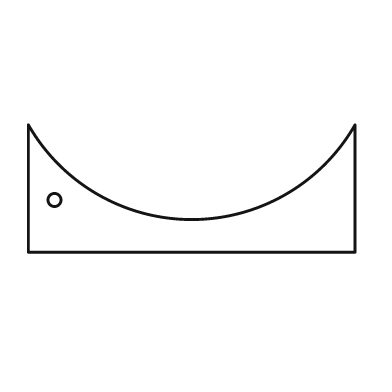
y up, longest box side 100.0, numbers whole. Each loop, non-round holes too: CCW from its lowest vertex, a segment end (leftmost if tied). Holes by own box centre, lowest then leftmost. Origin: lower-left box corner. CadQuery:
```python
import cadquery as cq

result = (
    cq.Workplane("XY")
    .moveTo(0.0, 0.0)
    .lineTo(100.0, 0.0)
    .lineTo(100.0, 39.0)
    .threePointArc((50.0, 10.0), (0.0, 39.0))
    .close()
    .moveTo(8.0, 16.0)
    .circle(2.0)
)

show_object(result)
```